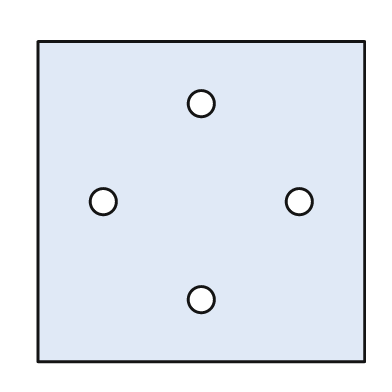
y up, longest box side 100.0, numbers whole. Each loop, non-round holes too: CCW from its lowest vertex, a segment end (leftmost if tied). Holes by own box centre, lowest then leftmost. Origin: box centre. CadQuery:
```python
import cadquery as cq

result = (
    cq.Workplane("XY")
    .moveTo(-50.0, -49.0)
    .lineTo(50.0, -49.0)
    .lineTo(50.0, 49.0)
    .lineTo(-50.0, 49.0)
    .close()
    .moveTo(0.0, -30.0)
    .circle(4.0)
    .moveTo(-30.0, 0.0)
    .circle(4.0)
    .moveTo(30.0, 0.0)
    .circle(4.0)
    .moveTo(0.0, 30.0)
    .circle(4.0)
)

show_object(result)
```